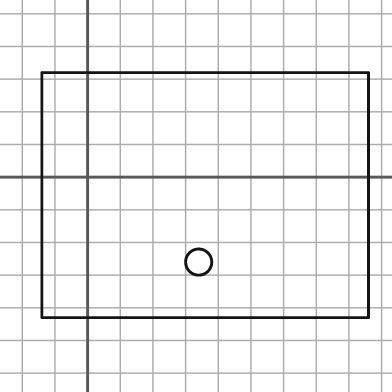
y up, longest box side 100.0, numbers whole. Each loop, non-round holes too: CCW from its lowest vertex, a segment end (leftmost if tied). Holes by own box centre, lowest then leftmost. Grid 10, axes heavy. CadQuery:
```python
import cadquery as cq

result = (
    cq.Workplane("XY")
    .moveTo(-14.0, -43.0)
    .lineTo(86.0, -43.0)
    .lineTo(86.0, 32.0)
    .lineTo(-14.0, 32.0)
    .close()
    .moveTo(34.0, -26.0)
    .circle(4.0)
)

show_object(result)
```